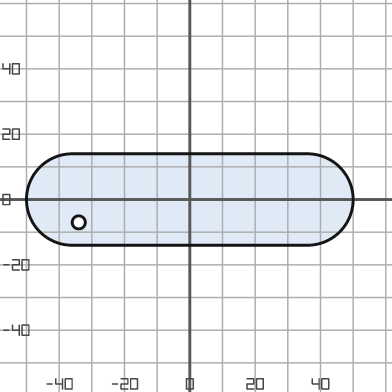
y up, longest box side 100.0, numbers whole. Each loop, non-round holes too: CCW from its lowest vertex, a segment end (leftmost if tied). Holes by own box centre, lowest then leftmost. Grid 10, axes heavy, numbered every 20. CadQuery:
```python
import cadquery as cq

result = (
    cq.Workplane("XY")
    .moveTo(-36.0, -14.0)
    .lineTo(36.0, -14.0)
    .threePointArc((50.0, 0.0), (36.0, 14.0))
    .lineTo(-36.0, 14.0)
    .threePointArc((-50.0, 0.0), (-36.0, -14.0))
    .close()
    .moveTo(-34.0, -7.0)
    .circle(2.0)
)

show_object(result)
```